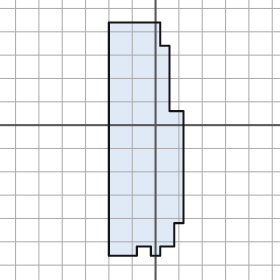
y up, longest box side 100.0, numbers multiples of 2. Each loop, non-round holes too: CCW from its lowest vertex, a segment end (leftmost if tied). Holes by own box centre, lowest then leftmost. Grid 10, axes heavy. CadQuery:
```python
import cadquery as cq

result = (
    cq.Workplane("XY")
    .moveTo(-20.0, -56.0)
    .lineTo(-8.0, -56.0)
    .lineTo(-8.0, -52.0)
    .lineTo(-2.0, -52.0)
    .lineTo(-2.0, -56.0)
    .lineTo(2.0, -56.0)
    .lineTo(2.0, -52.0)
    .lineTo(8.0, -52.0)
    .lineTo(8.0, -42.0)
    .lineTo(12.0, -42.0)
    .lineTo(12.0, 6.0)
    .lineTo(6.0, 6.0)
    .lineTo(6.0, 34.0)
    .lineTo(2.0, 34.0)
    .lineTo(2.0, 44.0)
    .lineTo(-20.0, 44.0)
    .close()
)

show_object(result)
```